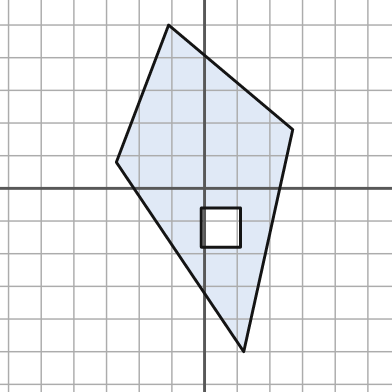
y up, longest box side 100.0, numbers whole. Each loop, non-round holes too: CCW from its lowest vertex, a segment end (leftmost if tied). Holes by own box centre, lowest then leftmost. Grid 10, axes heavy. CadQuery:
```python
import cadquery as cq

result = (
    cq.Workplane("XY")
    .moveTo(12.0, -50.0)
    .lineTo(27.0, 18.0)
    .lineTo(-11.0, 50.0)
    .lineTo(-27.0, 8.0)
    .close()
    .moveTo(-1.0, -18.0)
    .lineTo(11.0, -18.0)
    .lineTo(11.0, -6.0)
    .lineTo(-1.0, -6.0)
    .close()
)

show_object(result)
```